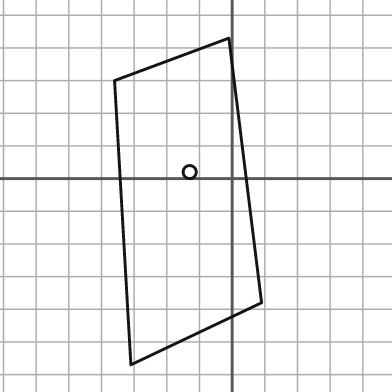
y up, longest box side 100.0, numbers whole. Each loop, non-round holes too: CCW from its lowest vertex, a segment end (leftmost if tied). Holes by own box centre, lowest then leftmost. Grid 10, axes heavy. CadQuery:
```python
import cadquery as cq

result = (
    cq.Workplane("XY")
    .moveTo(-31.0, -57.0)
    .lineTo(9.0, -38.0)
    .lineTo(-1.0, 43.0)
    .lineTo(-36.0, 30.0)
    .close()
    .moveTo(-13.0, 2.0)
    .circle(2.0)
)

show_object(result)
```